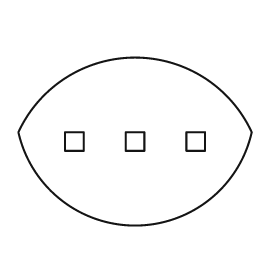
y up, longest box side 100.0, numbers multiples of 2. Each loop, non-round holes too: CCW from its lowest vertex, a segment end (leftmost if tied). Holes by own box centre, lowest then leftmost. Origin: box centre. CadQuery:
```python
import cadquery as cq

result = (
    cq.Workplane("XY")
    .moveTo(-50.0, 4.0)
    .threePointArc((0.0, -36.0), (50.0, 4.0))
    .threePointArc((0.0, 36.0), (-50.0, 4.0))
    .close()
    .moveTo(-30.0, -4.0)
    .lineTo(-22.0, -4.0)
    .lineTo(-22.0, 4.0)
    .lineTo(-30.0, 4.0)
    .close()
    .moveTo(-4.0, -4.0)
    .lineTo(4.0, -4.0)
    .lineTo(4.0, 4.0)
    .lineTo(-4.0, 4.0)
    .close()
    .moveTo(22.0, -4.0)
    .lineTo(30.0, -4.0)
    .lineTo(30.0, 4.0)
    .lineTo(22.0, 4.0)
    .close()
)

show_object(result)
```